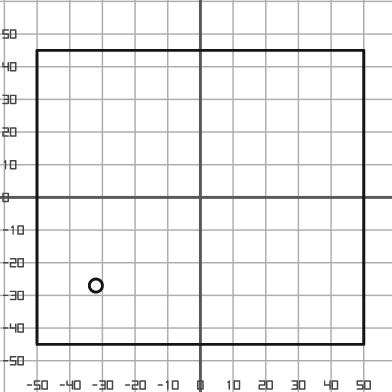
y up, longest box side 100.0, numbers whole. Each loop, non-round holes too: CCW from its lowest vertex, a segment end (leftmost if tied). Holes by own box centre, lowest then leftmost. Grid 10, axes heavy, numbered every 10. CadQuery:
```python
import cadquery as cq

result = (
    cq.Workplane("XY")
    .moveTo(-50.0, -45.0)
    .lineTo(50.0, -45.0)
    .lineTo(50.0, 45.0)
    .lineTo(-50.0, 45.0)
    .close()
    .moveTo(-32.0, -27.0)
    .circle(2.0)
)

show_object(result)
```